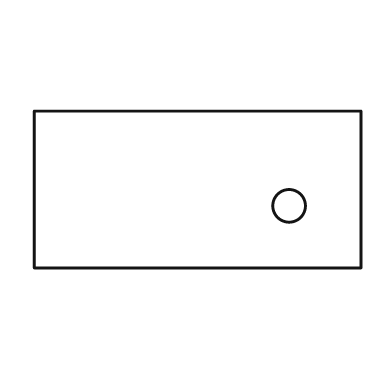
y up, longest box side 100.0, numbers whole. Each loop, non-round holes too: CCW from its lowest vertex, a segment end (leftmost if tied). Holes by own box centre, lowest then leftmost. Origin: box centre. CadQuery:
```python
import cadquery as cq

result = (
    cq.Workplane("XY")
    .moveTo(-50.0, -24.0)
    .lineTo(50.0, -24.0)
    .lineTo(50.0, 24.0)
    .lineTo(-50.0, 24.0)
    .close()
    .moveTo(28.0, -5.0)
    .circle(5.0)
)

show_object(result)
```